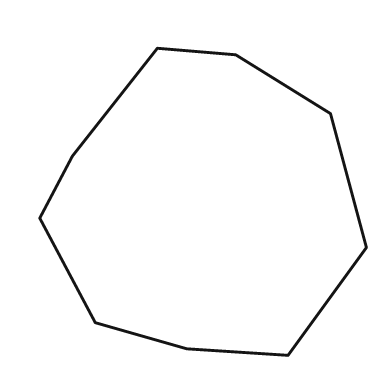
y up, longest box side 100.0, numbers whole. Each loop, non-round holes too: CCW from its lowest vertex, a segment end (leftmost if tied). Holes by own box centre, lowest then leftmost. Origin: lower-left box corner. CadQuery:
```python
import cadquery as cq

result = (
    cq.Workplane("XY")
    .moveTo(76.0, 0.0)
    .lineTo(100.0, 33.0)
    .lineTo(89.0, 74.0)
    .lineTo(60.0, 92.0)
    .lineTo(36.0, 94.0)
    .lineTo(10.0, 61.0)
    .lineTo(0.0, 42.0)
    .lineTo(17.0, 10.0)
    .lineTo(45.0, 2.0)
    .close()
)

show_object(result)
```